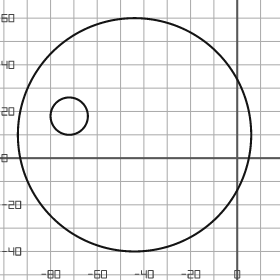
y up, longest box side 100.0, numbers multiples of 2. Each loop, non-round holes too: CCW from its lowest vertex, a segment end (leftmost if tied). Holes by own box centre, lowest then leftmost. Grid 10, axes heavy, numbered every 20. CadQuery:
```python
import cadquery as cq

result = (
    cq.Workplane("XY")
    .moveTo(-44.0, 10.0)
    .circle(50.0)
    .moveTo(-72.0, 18.0)
    .circle(8.0)
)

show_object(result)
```